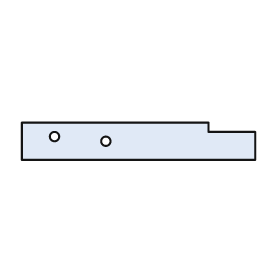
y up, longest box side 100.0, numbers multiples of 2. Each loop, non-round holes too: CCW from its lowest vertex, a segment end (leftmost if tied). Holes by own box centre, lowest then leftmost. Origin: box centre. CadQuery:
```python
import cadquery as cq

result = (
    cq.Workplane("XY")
    .moveTo(-50.0, -8.0)
    .lineTo(50.0, -8.0)
    .lineTo(50.0, 4.0)
    .lineTo(30.0, 4.0)
    .lineTo(30.0, 8.0)
    .lineTo(-50.0, 8.0)
    .close()
    .moveTo(-14.0, 0.0)
    .circle(2.0)
    .moveTo(-36.0, 2.0)
    .circle(2.0)
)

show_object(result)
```